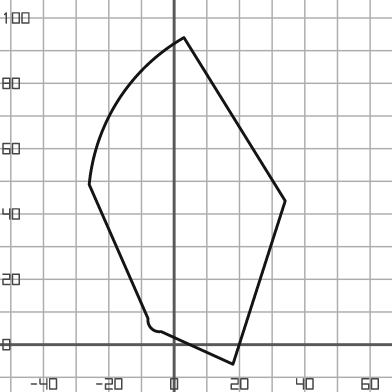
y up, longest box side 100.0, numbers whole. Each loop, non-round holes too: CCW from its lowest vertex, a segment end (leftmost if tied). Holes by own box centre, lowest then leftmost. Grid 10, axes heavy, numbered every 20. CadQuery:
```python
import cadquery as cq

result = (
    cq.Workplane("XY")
    .moveTo(18.0, -6.0)
    .lineTo(34.0, 44.0)
    .lineTo(3.0, 94.0)
    .threePointArc((-17.0, 75.0), (-26.0, 49.0))
    .lineTo(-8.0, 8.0)
    .threePointArc((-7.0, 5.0), (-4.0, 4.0))
    .close()
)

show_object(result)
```